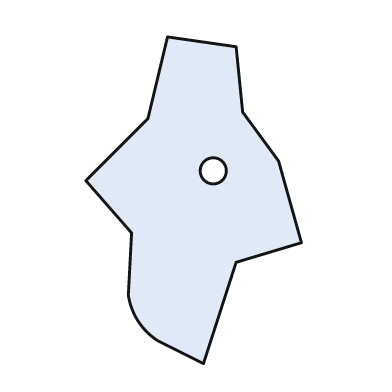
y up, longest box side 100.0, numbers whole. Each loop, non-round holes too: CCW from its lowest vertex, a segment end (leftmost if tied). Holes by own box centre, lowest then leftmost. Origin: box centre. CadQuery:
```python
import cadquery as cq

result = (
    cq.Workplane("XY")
    .moveTo(3.0, -50.0)
    .lineTo(13.0, -19.0)
    .lineTo(33.0, -13.0)
    .lineTo(26.0, 12.0)
    .lineTo(15.0, 27.0)
    .lineTo(13.0, 47.0)
    .lineTo(-8.0, 50.0)
    .lineTo(-14.0, 25.0)
    .lineTo(-33.0, 6.0)
    .lineTo(-19.0, -10.0)
    .lineTo(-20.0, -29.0)
    .threePointArc((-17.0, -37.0), (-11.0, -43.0))
    .close()
    .moveTo(6.0, 9.0)
    .circle(4.0)
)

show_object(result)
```